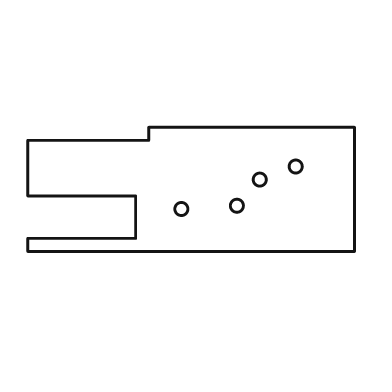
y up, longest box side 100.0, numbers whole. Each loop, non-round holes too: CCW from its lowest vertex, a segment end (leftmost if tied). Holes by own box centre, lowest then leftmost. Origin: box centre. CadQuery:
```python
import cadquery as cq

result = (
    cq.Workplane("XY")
    .moveTo(-50.0, -19.0)
    .lineTo(50.0, -19.0)
    .lineTo(50.0, 19.0)
    .lineTo(-13.0, 19.0)
    .lineTo(-13.0, 15.0)
    .lineTo(-50.0, 15.0)
    .lineTo(-50.0, -2.0)
    .lineTo(-17.0, -2.0)
    .lineTo(-17.0, -15.0)
    .lineTo(-50.0, -15.0)
    .close()
    .moveTo(-3.0, -6.0)
    .circle(2.0)
    .moveTo(14.0, -5.0)
    .circle(2.0)
    .moveTo(21.0, 3.0)
    .circle(2.0)
    .moveTo(32.0, 7.0)
    .circle(2.0)
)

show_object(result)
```